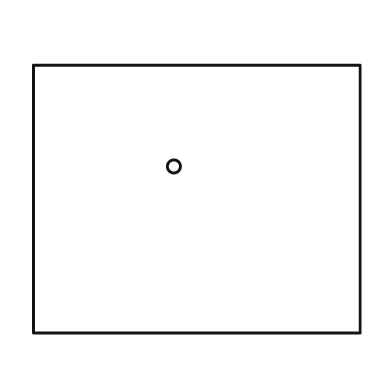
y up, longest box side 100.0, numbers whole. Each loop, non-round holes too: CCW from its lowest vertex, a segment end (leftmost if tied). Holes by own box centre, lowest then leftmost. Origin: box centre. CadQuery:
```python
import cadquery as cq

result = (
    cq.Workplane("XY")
    .moveTo(-50.0, -41.0)
    .lineTo(50.0, -41.0)
    .lineTo(50.0, 41.0)
    .lineTo(-50.0, 41.0)
    .close()
    .moveTo(-7.0, 10.0)
    .circle(2.0)
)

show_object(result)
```